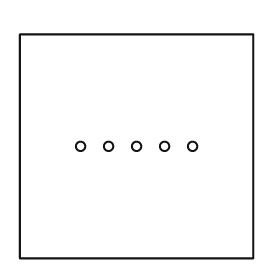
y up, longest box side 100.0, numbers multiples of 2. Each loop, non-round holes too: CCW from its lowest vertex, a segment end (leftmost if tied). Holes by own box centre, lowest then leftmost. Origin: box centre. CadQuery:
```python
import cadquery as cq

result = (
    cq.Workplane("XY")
    .moveTo(-50.0, -48.0)
    .lineTo(50.0, -48.0)
    .lineTo(50.0, 48.0)
    .lineTo(-50.0, 48.0)
    .close()
    .moveTo(-24.0, 0.0)
    .circle(2.0)
    .moveTo(-12.0, 0.0)
    .circle(2.0)
    .moveTo(0.0, 0.0)
    .circle(2.0)
    .moveTo(12.0, 0.0)
    .circle(2.0)
    .moveTo(24.0, 0.0)
    .circle(2.0)
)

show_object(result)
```